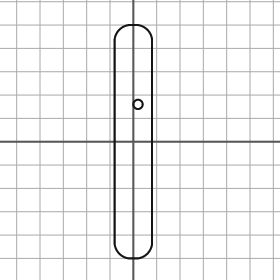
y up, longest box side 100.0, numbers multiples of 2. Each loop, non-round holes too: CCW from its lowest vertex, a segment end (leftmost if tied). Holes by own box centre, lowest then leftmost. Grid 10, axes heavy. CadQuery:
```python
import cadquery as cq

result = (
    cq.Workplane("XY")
    .moveTo(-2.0, -50.0)
    .lineTo(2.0, -50.0)
    .threePointArc((6.0, -48.0), (8.0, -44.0))
    .lineTo(8.0, 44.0)
    .threePointArc((6.0, 48.0), (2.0, 50.0))
    .lineTo(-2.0, 50.0)
    .threePointArc((-6.0, 48.0), (-8.0, 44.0))
    .lineTo(-8.0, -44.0)
    .threePointArc((-6.0, -48.0), (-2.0, -50.0))
    .close()
    .moveTo(2.0, 16.0)
    .circle(2.0)
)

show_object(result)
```